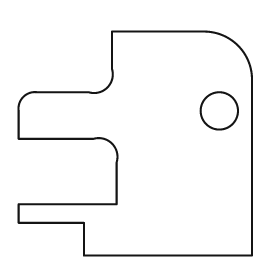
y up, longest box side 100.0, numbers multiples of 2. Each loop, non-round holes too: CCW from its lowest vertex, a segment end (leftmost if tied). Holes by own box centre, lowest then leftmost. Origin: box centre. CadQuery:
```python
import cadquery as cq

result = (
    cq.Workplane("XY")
    .moveTo(-22.0, -48.0)
    .lineTo(50.0, -48.0)
    .lineTo(50.0, 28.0)
    .threePointArc((44.0, 42.0), (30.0, 48.0))
    .lineTo(-10.0, 48.0)
    .lineTo(-10.0, 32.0)
    .threePointArc((-12.0, 24.0), (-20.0, 22.0))
    .lineTo(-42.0, 22.0)
    .threePointArc((-48.0, 20.0), (-50.0, 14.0))
    .lineTo(-50.0, 2.0)
    .lineTo(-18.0, 2.0)
    .threePointArc((-10.0, 0.0), (-8.0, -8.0))
    .lineTo(-8.0, -26.0)
    .lineTo(-50.0, -26.0)
    .lineTo(-50.0, -34.0)
    .lineTo(-22.0, -34.0)
    .close()
    .moveTo(36.0, 14.0)
    .circle(8.0)
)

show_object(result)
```